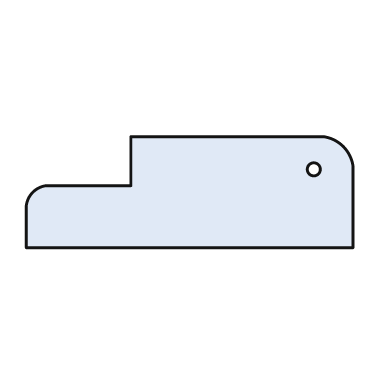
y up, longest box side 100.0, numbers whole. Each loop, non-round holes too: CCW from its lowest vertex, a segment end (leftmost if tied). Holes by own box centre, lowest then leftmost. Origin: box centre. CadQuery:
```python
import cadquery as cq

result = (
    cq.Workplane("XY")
    .moveTo(-50.0, -17.0)
    .lineTo(50.0, -17.0)
    .lineTo(50.0, 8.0)
    .threePointArc((47.0, 14.0), (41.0, 17.0))
    .lineTo(-18.0, 17.0)
    .lineTo(-18.0, 2.0)
    .lineTo(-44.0, 2.0)
    .threePointArc((-48.0, 0.0), (-50.0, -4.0))
    .close()
    .moveTo(38.0, 7.0)
    .circle(2.0)
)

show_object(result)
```